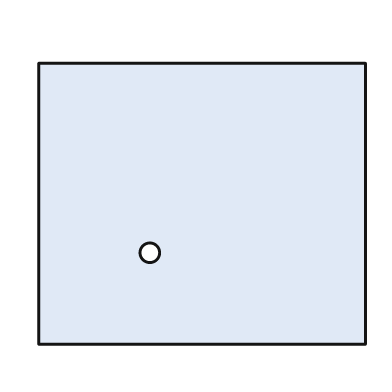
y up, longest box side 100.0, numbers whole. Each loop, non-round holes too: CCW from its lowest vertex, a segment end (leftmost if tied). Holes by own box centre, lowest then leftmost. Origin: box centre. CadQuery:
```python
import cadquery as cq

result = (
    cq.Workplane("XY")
    .moveTo(-50.0, -43.0)
    .lineTo(50.0, -43.0)
    .lineTo(50.0, 43.0)
    .lineTo(-50.0, 43.0)
    .close()
    .moveTo(-16.0, -15.0)
    .circle(3.0)
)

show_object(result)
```